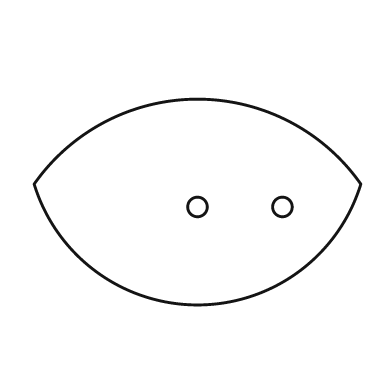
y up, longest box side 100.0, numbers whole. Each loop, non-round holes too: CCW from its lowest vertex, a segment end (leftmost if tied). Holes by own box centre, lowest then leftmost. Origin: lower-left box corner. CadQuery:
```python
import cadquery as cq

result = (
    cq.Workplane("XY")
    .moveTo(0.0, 37.0)
    .threePointArc((50.0, 0.0), (100.0, 37.0))
    .threePointArc((50.0, 63.0), (0.0, 37.0))
    .close()
    .moveTo(50.0, 30.0)
    .circle(3.0)
    .moveTo(76.0, 30.0)
    .circle(3.0)
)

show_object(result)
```